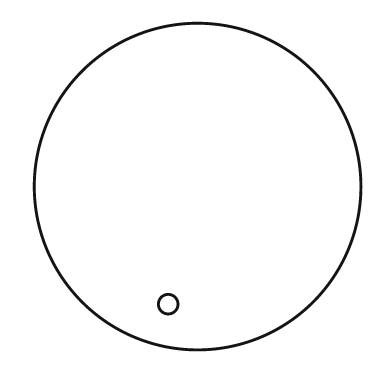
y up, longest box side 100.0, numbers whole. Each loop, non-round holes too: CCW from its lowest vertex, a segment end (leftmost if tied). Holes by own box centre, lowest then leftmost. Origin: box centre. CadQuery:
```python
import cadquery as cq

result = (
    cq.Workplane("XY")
    .moveTo(0.0, 0.0)
    .circle(50.0)
    .moveTo(-9.0, -36.0)
    .circle(3.0)
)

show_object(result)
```